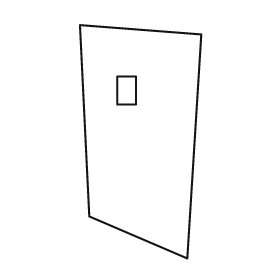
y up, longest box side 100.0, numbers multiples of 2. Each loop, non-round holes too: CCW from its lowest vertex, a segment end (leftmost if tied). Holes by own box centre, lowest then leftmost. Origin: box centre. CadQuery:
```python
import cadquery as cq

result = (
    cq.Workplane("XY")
    .moveTo(20.0, -50.0)
    .lineTo(26.0, 46.0)
    .lineTo(-26.0, 50.0)
    .lineTo(-22.0, -32.0)
    .close()
    .moveTo(-10.0, 16.0)
    .lineTo(-2.0, 16.0)
    .lineTo(-2.0, 28.0)
    .lineTo(-10.0, 28.0)
    .close()
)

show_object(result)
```